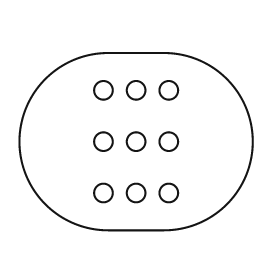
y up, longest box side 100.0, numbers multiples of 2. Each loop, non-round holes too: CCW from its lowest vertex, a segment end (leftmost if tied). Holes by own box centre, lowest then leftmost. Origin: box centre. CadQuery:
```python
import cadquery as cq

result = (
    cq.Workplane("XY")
    .moveTo(-12.0, -38.0)
    .lineTo(12.0, -38.0)
    .threePointArc((50.0, 0.0), (12.0, 38.0))
    .lineTo(-12.0, 38.0)
    .threePointArc((-50.0, 0.0), (-12.0, -38.0))
    .close()
    .moveTo(-14.0, -22.0)
    .circle(4.0)
    .moveTo(0.0, -22.0)
    .circle(4.0)
    .moveTo(14.0, -22.0)
    .circle(4.0)
    .moveTo(-14.0, 0.0)
    .circle(4.0)
    .moveTo(0.0, 0.0)
    .circle(4.0)
    .moveTo(14.0, 0.0)
    .circle(4.0)
    .moveTo(-14.0, 22.0)
    .circle(4.0)
    .moveTo(0.0, 22.0)
    .circle(4.0)
    .moveTo(14.0, 22.0)
    .circle(4.0)
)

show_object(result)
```